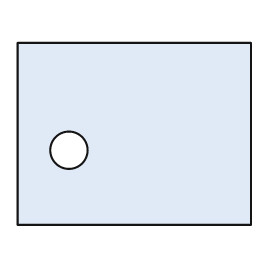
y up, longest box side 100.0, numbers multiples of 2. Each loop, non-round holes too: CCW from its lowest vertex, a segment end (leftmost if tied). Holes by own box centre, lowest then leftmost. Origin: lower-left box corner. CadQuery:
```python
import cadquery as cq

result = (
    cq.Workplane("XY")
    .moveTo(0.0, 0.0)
    .lineTo(100.0, 0.0)
    .lineTo(100.0, 78.0)
    .lineTo(0.0, 78.0)
    .close()
    .moveTo(22.0, 32.0)
    .circle(8.0)
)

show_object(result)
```